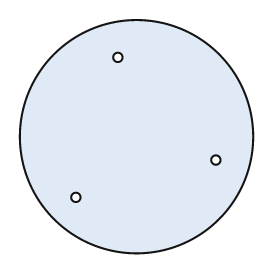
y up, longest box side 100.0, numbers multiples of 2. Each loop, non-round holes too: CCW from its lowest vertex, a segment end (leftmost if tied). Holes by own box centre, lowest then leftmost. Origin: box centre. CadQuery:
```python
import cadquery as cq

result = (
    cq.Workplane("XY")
    .moveTo(0.0, 0.0)
    .circle(50.0)
    .moveTo(-26.0, -26.0)
    .circle(2.0)
    .moveTo(34.0, -10.0)
    .circle(2.0)
    .moveTo(-8.0, 34.0)
    .circle(2.0)
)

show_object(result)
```